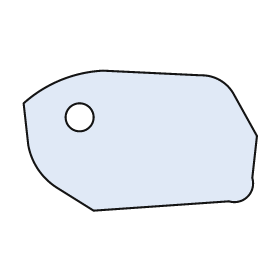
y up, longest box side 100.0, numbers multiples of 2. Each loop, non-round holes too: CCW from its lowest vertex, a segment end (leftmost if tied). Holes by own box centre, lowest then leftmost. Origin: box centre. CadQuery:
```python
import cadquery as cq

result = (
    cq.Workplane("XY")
    .moveTo(-20.0, -30.0)
    .lineTo(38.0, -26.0)
    .threePointArc((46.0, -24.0), (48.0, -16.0))
    .lineTo(50.0, 2.0)
    .lineTo(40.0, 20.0)
    .threePointArc((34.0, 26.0), (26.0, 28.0))
    .lineTo(-16.0, 30.0)
    .threePointArc((-34.0, 26.0), (-50.0, 16.0))
    .lineTo(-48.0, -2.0)
    .threePointArc((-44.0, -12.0), (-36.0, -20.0))
    .close()
    .moveTo(-26.0, 10.0)
    .circle(6.0)
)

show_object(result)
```